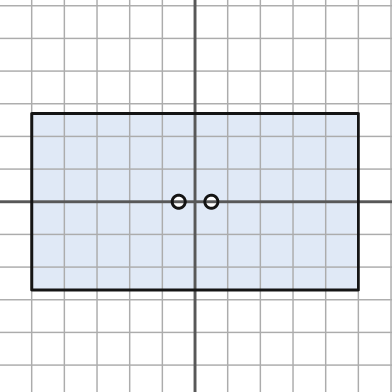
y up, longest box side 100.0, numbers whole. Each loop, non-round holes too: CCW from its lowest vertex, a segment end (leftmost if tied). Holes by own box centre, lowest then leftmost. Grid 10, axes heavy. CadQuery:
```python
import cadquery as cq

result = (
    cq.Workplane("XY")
    .moveTo(-50.0, -27.0)
    .lineTo(50.0, -27.0)
    .lineTo(50.0, 27.0)
    .lineTo(-50.0, 27.0)
    .close()
    .moveTo(-5.0, 0.0)
    .circle(2.0)
    .moveTo(5.0, 0.0)
    .circle(2.0)
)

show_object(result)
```